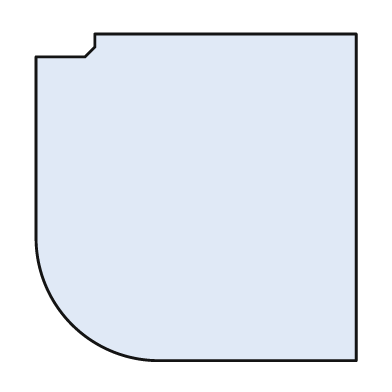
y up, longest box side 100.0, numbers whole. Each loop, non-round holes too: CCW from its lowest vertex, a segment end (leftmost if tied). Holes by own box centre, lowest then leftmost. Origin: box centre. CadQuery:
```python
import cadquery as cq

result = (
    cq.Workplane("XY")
    .moveTo(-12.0, -50.0)
    .lineTo(49.0, -50.0)
    .lineTo(49.0, 50.0)
    .lineTo(-31.0, 50.0)
    .lineTo(-31.0, 46.0)
    .lineTo(-34.0, 43.0)
    .lineTo(-49.0, 43.0)
    .lineTo(-49.0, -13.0)
    .threePointArc((-38.0, -39.0), (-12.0, -50.0))
    .close()
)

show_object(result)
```